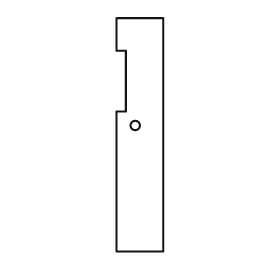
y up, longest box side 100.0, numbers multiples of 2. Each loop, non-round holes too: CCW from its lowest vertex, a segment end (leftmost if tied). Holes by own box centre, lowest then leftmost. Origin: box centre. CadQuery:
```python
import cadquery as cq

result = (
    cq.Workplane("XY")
    .moveTo(-10.0, -50.0)
    .lineTo(10.0, -50.0)
    .lineTo(10.0, 50.0)
    .lineTo(-10.0, 50.0)
    .lineTo(-10.0, 36.0)
    .lineTo(-6.0, 36.0)
    .lineTo(-6.0, 10.0)
    .lineTo(-10.0, 10.0)
    .close()
    .moveTo(-2.0, 4.0)
    .circle(2.0)
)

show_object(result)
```